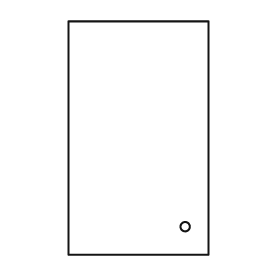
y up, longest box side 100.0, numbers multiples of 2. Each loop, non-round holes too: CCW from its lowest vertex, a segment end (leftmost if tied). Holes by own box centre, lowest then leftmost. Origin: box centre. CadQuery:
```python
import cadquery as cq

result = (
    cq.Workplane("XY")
    .moveTo(-30.0, -50.0)
    .lineTo(30.0, -50.0)
    .lineTo(30.0, 50.0)
    .lineTo(-30.0, 50.0)
    .close()
    .moveTo(20.0, -38.0)
    .circle(2.0)
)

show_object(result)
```